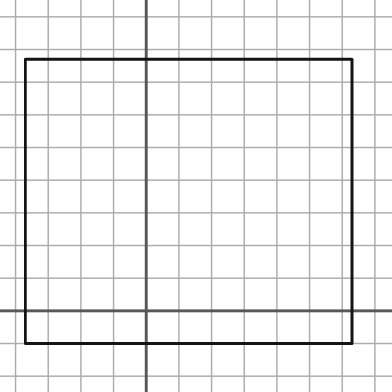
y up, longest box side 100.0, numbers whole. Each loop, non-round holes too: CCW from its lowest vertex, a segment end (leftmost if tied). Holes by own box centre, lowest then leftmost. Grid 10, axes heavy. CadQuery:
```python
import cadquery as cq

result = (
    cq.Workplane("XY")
    .moveTo(-37.0, -10.0)
    .lineTo(63.0, -10.0)
    .lineTo(63.0, 77.0)
    .lineTo(-37.0, 77.0)
    .close()
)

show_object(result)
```